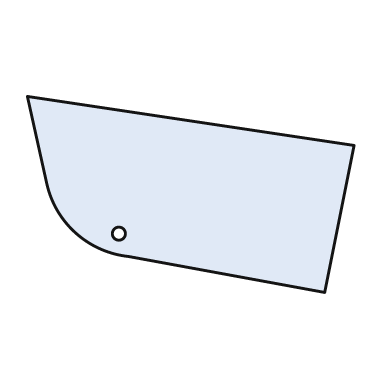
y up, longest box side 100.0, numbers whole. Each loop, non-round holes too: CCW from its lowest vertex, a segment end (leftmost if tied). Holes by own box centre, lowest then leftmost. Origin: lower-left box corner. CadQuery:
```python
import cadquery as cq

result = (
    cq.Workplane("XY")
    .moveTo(91.0, 0.0)
    .lineTo(100.0, 45.0)
    .lineTo(0.0, 60.0)
    .lineTo(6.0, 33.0)
    .threePointArc((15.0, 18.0), (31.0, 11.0))
    .close()
    .moveTo(28.0, 18.0)
    .circle(2.0)
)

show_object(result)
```